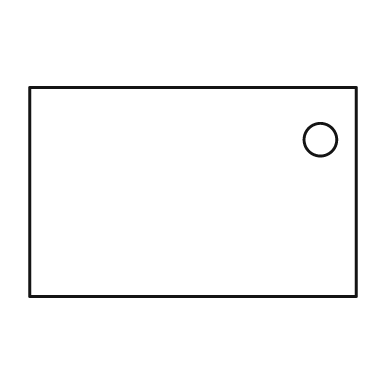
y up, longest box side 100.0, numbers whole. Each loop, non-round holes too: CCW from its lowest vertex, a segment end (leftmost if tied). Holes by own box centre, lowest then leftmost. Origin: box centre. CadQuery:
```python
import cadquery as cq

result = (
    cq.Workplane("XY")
    .moveTo(-50.0, -32.0)
    .lineTo(50.0, -32.0)
    .lineTo(50.0, 32.0)
    .lineTo(-50.0, 32.0)
    .close()
    .moveTo(39.0, 16.0)
    .circle(5.0)
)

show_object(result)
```